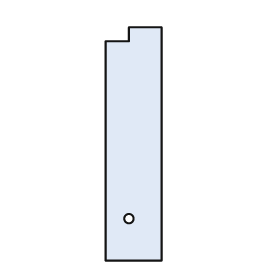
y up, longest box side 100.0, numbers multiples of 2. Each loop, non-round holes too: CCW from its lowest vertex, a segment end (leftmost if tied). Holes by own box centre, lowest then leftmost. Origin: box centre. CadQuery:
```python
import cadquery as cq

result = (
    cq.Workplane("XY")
    .moveTo(-12.0, -50.0)
    .lineTo(12.0, -50.0)
    .lineTo(12.0, 50.0)
    .lineTo(-2.0, 50.0)
    .lineTo(-2.0, 44.0)
    .lineTo(-12.0, 44.0)
    .close()
    .moveTo(-2.0, -32.0)
    .circle(2.0)
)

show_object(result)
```